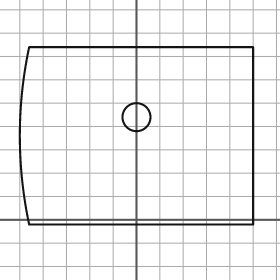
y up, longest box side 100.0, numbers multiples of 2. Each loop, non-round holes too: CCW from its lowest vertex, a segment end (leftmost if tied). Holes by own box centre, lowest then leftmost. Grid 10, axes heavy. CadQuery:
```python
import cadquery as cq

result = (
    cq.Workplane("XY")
    .moveTo(-46.0, -2.0)
    .lineTo(50.0, -2.0)
    .lineTo(50.0, 74.0)
    .lineTo(-46.0, 74.0)
    .threePointArc((-50.0, 36.0), (-46.0, -2.0))
    .close()
    .moveTo(0.0, 44.0)
    .circle(6.0)
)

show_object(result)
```